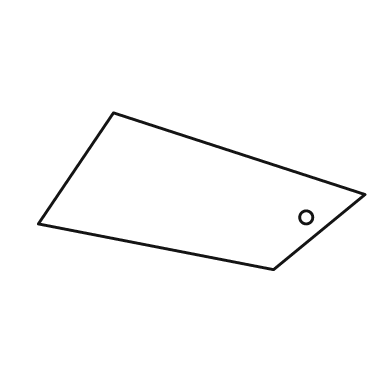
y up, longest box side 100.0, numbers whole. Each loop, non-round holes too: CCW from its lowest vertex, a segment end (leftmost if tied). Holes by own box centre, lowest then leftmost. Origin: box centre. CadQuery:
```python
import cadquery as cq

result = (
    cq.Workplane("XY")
    .moveTo(22.0, -24.0)
    .lineTo(50.0, -1.0)
    .lineTo(-27.0, 24.0)
    .lineTo(-50.0, -10.0)
    .close()
    .moveTo(32.0, -8.0)
    .circle(2.0)
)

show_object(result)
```